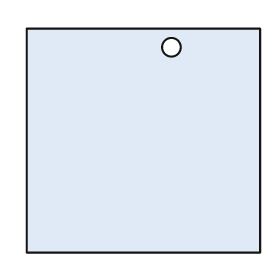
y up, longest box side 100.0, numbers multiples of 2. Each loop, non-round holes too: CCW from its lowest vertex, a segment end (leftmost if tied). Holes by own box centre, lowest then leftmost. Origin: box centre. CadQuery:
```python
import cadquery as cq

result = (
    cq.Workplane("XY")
    .moveTo(-50.0, -48.0)
    .lineTo(50.0, -48.0)
    .lineTo(50.0, 48.0)
    .lineTo(-50.0, 48.0)
    .close()
    .moveTo(12.0, 40.0)
    .circle(4.0)
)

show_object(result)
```